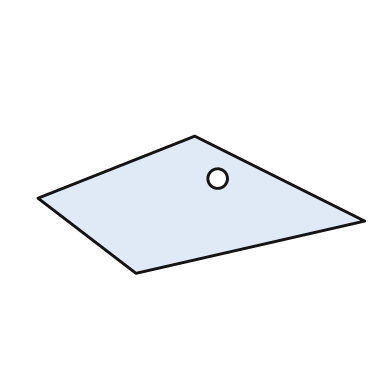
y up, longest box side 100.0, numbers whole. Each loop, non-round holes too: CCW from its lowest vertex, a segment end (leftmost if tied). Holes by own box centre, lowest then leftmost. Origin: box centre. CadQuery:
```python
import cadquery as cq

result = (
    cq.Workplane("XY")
    .moveTo(-20.0, -21.0)
    .lineTo(50.0, -5.0)
    .lineTo(-2.0, 21.0)
    .lineTo(-50.0, 2.0)
    .close()
    .moveTo(5.0, 8.0)
    .circle(3.0)
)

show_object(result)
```